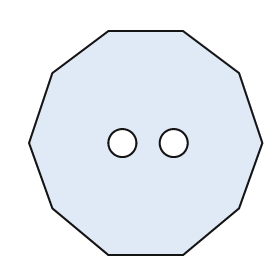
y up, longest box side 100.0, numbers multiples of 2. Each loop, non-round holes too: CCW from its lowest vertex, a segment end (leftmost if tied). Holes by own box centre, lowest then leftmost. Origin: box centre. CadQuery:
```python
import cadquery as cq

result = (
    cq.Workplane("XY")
    .moveTo(-16.0, -48.0)
    .lineTo(16.0, -48.0)
    .lineTo(40.0, -28.0)
    .lineTo(50.0, 0.0)
    .lineTo(40.0, 30.0)
    .lineTo(16.0, 48.0)
    .lineTo(-16.0, 48.0)
    .lineTo(-40.0, 30.0)
    .lineTo(-50.0, 0.0)
    .lineTo(-40.0, -28.0)
    .close()
    .moveTo(-10.0, 0.0)
    .circle(6.0)
    .moveTo(12.0, 0.0)
    .circle(6.0)
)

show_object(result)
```